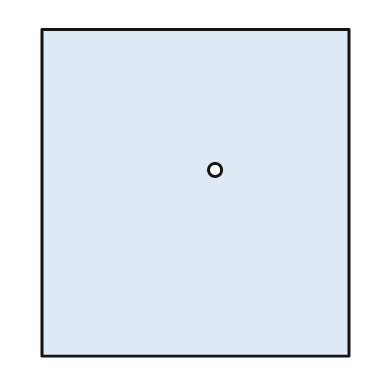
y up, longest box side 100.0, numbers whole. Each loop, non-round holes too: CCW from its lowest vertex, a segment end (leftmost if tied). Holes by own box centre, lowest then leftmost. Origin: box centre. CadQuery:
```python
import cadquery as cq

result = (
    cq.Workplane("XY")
    .moveTo(-47.0, -50.0)
    .lineTo(47.0, -50.0)
    .lineTo(47.0, 50.0)
    .lineTo(-47.0, 50.0)
    .close()
    .moveTo(6.0, 7.0)
    .circle(2.0)
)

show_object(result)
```